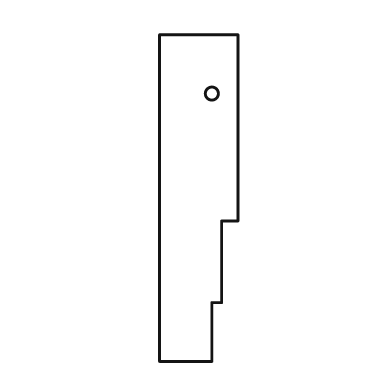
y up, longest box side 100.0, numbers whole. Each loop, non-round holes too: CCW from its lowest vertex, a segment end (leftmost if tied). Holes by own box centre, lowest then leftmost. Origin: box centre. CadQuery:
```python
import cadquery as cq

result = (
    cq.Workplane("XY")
    .moveTo(-12.0, -50.0)
    .lineTo(4.0, -50.0)
    .lineTo(4.0, -32.0)
    .lineTo(7.0, -32.0)
    .lineTo(7.0, -7.0)
    .lineTo(12.0, -7.0)
    .lineTo(12.0, 50.0)
    .lineTo(-12.0, 50.0)
    .close()
    .moveTo(4.0, 32.0)
    .circle(2.0)
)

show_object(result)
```